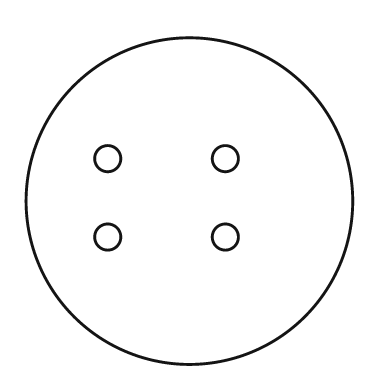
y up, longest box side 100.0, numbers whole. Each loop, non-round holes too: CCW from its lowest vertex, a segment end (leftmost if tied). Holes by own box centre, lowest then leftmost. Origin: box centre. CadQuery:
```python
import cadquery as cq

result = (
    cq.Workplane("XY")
    .moveTo(0.0, 0.0)
    .circle(50.0)
    .moveTo(-25.0, -11.0)
    .circle(4.0)
    .moveTo(11.0, -11.0)
    .circle(4.0)
    .moveTo(-25.0, 13.0)
    .circle(4.0)
    .moveTo(11.0, 13.0)
    .circle(4.0)
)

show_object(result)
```